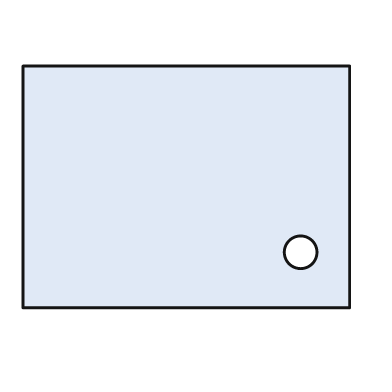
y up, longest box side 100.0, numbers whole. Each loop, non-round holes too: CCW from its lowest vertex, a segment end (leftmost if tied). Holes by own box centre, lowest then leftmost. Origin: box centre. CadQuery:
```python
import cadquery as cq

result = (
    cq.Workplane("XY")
    .moveTo(-50.0, -37.0)
    .lineTo(50.0, -37.0)
    .lineTo(50.0, 37.0)
    .lineTo(-50.0, 37.0)
    .close()
    .moveTo(35.0, -20.0)
    .circle(5.0)
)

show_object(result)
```